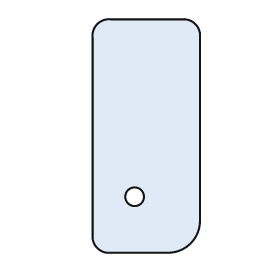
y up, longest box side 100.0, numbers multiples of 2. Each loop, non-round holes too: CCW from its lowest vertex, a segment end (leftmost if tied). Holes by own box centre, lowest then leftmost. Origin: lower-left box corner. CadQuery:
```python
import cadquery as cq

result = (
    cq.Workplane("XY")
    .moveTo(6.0, 0.0)
    .lineTo(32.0, 0.0)
    .threePointArc((42.0, 4.0), (46.0, 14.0))
    .lineTo(46.0, 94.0)
    .threePointArc((44.0, 98.0), (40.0, 100.0))
    .lineTo(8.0, 100.0)
    .threePointArc((2.0, 98.0), (0.0, 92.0))
    .lineTo(0.0, 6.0)
    .threePointArc((2.0, 2.0), (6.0, 0.0))
    .close()
    .moveTo(18.0, 24.0)
    .circle(4.0)
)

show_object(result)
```